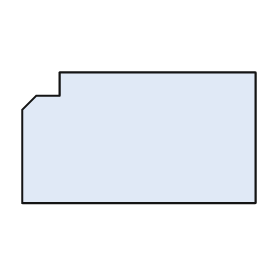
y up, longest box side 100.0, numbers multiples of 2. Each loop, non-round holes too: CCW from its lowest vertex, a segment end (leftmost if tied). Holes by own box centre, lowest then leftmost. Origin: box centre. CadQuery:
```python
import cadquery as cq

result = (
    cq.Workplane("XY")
    .moveTo(-50.0, -28.0)
    .lineTo(50.0, -28.0)
    .lineTo(50.0, 28.0)
    .lineTo(-34.0, 28.0)
    .lineTo(-34.0, 18.0)
    .lineTo(-44.0, 18.0)
    .lineTo(-50.0, 12.0)
    .close()
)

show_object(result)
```